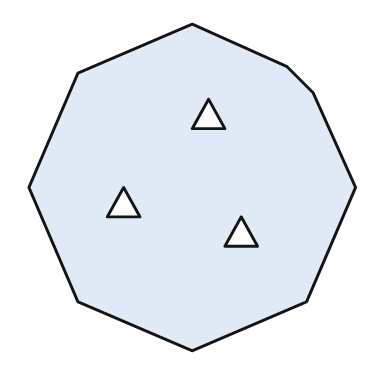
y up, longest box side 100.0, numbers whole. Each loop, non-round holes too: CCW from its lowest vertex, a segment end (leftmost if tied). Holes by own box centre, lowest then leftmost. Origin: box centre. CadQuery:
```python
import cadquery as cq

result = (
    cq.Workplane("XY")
    .moveTo(0.0, -50.0)
    .lineTo(35.0, -35.0)
    .lineTo(50.0, 0.0)
    .lineTo(37.0, 29.0)
    .lineTo(29.0, 37.0)
    .lineTo(0.0, 50.0)
    .lineTo(-35.0, 35.0)
    .lineTo(-50.0, 0.0)
    .lineTo(-35.0, -35.0)
    .close()
    .moveTo(10.0, -18.0)
    .lineTo(20.0, -18.0)
    .lineTo(15.0, -9.0)
    .close()
    .moveTo(-26.0, -9.0)
    .lineTo(-16.0, -9.0)
    .lineTo(-21.0, 0.0)
    .close()
    .moveTo(0.0, 18.0)
    .lineTo(10.0, 18.0)
    .lineTo(5.0, 27.0)
    .close()
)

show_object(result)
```